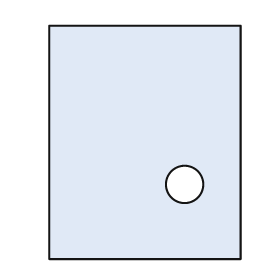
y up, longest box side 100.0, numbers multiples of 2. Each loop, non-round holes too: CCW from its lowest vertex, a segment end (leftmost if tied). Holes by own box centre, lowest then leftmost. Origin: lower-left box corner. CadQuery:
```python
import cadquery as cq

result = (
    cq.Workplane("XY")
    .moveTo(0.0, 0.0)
    .lineTo(82.0, 0.0)
    .lineTo(82.0, 100.0)
    .lineTo(0.0, 100.0)
    .close()
    .moveTo(58.0, 32.0)
    .circle(8.0)
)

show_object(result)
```